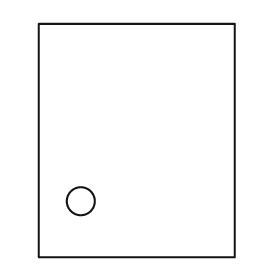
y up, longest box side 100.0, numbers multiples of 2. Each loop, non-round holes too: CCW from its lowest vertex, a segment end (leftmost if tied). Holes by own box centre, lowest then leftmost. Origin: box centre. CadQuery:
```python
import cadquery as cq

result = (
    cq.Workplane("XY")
    .moveTo(-42.0, -50.0)
    .lineTo(42.0, -50.0)
    .lineTo(42.0, 50.0)
    .lineTo(-42.0, 50.0)
    .close()
    .moveTo(-24.0, -26.0)
    .circle(6.0)
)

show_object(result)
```